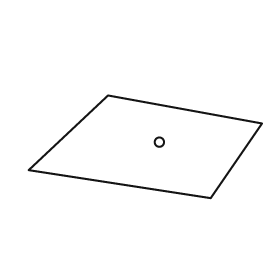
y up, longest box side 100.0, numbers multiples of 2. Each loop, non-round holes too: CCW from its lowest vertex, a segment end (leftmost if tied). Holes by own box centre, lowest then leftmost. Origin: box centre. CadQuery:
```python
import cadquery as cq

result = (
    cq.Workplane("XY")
    .moveTo(28.0, -22.0)
    .lineTo(50.0, 10.0)
    .lineTo(-16.0, 22.0)
    .lineTo(-50.0, -10.0)
    .close()
    .moveTo(6.0, 2.0)
    .circle(2.0)
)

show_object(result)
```